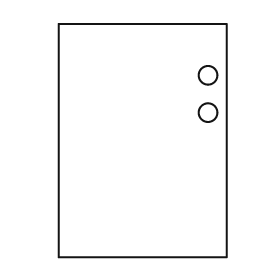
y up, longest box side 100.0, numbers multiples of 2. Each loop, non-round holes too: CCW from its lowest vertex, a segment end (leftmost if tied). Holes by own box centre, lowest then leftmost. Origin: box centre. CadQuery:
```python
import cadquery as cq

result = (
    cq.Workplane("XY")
    .moveTo(-36.0, -50.0)
    .lineTo(36.0, -50.0)
    .lineTo(36.0, 50.0)
    .lineTo(-36.0, 50.0)
    .close()
    .moveTo(28.0, 12.0)
    .circle(4.0)
    .moveTo(28.0, 28.0)
    .circle(4.0)
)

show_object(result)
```